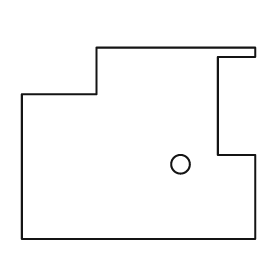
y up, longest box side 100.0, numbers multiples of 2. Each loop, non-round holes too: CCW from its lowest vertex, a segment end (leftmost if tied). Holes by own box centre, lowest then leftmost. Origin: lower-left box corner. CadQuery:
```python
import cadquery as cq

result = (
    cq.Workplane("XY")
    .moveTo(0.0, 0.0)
    .lineTo(100.0, 0.0)
    .lineTo(100.0, 36.0)
    .lineTo(84.0, 36.0)
    .lineTo(84.0, 78.0)
    .lineTo(100.0, 78.0)
    .lineTo(100.0, 82.0)
    .lineTo(32.0, 82.0)
    .lineTo(32.0, 62.0)
    .lineTo(0.0, 62.0)
    .close()
    .moveTo(68.0, 32.0)
    .circle(4.0)
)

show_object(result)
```